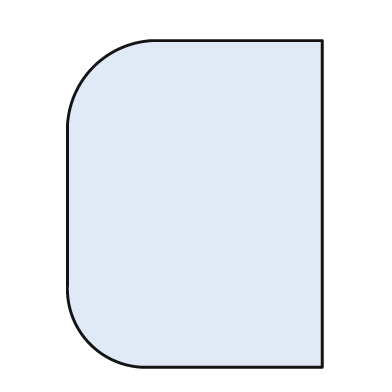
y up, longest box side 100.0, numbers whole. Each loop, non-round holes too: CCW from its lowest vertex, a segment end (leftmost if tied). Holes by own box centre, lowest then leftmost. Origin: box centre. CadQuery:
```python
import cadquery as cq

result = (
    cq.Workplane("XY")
    .moveTo(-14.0, -50.0)
    .lineTo(39.0, -50.0)
    .lineTo(39.0, 50.0)
    .lineTo(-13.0, 50.0)
    .threePointArc((-31.0, 42.0), (-39.0, 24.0))
    .lineTo(-39.0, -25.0)
    .threePointArc((-32.0, -43.0), (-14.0, -50.0))
    .close()
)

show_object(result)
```